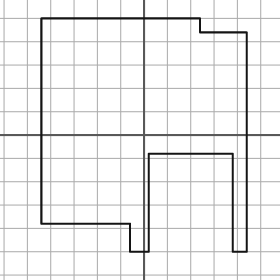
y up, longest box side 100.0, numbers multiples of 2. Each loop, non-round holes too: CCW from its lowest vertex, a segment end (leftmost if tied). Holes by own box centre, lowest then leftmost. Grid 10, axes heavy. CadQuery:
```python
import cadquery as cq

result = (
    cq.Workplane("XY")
    .moveTo(-6.0, -50.0)
    .lineTo(2.0, -50.0)
    .lineTo(2.0, -8.0)
    .lineTo(38.0, -8.0)
    .lineTo(38.0, -50.0)
    .lineTo(44.0, -50.0)
    .lineTo(44.0, 44.0)
    .lineTo(24.0, 44.0)
    .lineTo(24.0, 50.0)
    .lineTo(-44.0, 50.0)
    .lineTo(-44.0, -38.0)
    .lineTo(-6.0, -38.0)
    .close()
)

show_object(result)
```